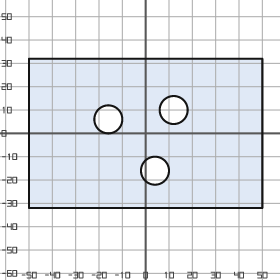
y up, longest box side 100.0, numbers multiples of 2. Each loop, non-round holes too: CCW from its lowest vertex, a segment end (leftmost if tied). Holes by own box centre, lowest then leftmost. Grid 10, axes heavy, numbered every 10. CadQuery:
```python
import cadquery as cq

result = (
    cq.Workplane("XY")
    .moveTo(-50.0, -32.0)
    .lineTo(50.0, -32.0)
    .lineTo(50.0, 32.0)
    .lineTo(-50.0, 32.0)
    .close()
    .moveTo(4.0, -16.0)
    .circle(6.0)
    .moveTo(-16.0, 6.0)
    .circle(6.0)
    .moveTo(12.0, 10.0)
    .circle(6.0)
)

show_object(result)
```